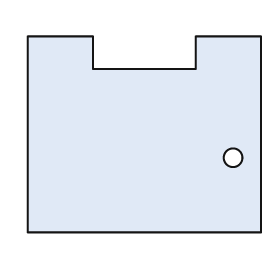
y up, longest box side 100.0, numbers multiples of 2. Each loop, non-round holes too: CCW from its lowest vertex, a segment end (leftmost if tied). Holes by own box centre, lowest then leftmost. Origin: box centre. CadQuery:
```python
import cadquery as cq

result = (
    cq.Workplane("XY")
    .moveTo(-50.0, -42.0)
    .lineTo(50.0, -42.0)
    .lineTo(50.0, 42.0)
    .lineTo(22.0, 42.0)
    .lineTo(22.0, 28.0)
    .lineTo(-22.0, 28.0)
    .lineTo(-22.0, 42.0)
    .lineTo(-50.0, 42.0)
    .close()
    .moveTo(38.0, -10.0)
    .circle(4.0)
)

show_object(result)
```